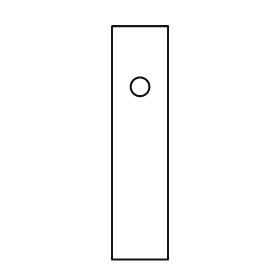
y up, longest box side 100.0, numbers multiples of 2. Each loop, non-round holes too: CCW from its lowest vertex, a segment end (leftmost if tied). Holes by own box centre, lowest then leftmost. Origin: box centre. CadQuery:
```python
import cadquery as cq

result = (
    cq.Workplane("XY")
    .moveTo(-12.0, -50.0)
    .lineTo(12.0, -50.0)
    .lineTo(12.0, 50.0)
    .lineTo(-12.0, 50.0)
    .close()
    .moveTo(0.0, 24.0)
    .circle(4.0)
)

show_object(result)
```